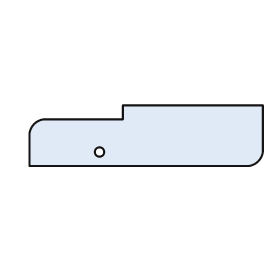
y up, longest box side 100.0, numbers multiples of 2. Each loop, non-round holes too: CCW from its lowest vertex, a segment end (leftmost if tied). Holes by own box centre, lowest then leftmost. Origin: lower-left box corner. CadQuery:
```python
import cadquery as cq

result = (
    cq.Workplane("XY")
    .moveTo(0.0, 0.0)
    .lineTo(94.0, 0.0)
    .threePointArc((98.0, 2.0), (100.0, 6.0))
    .lineTo(100.0, 26.0)
    .lineTo(40.0, 26.0)
    .lineTo(40.0, 20.0)
    .lineTo(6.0, 20.0)
    .threePointArc((2.0, 18.0), (0.0, 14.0))
    .close()
    .moveTo(30.0, 6.0)
    .circle(2.0)
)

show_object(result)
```